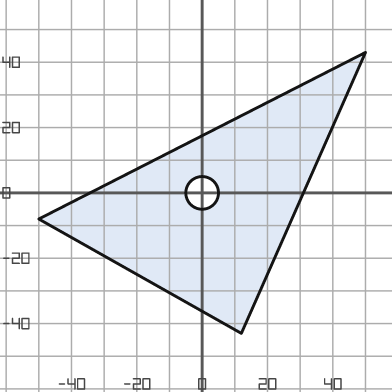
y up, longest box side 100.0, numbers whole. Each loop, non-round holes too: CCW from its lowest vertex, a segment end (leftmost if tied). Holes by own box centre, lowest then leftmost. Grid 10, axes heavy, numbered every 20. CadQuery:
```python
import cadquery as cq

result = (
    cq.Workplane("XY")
    .moveTo(12.0, -43.0)
    .lineTo(50.0, 43.0)
    .lineTo(-50.0, -8.0)
    .close()
    .moveTo(0.0, 0.0)
    .circle(5.0)
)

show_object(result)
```